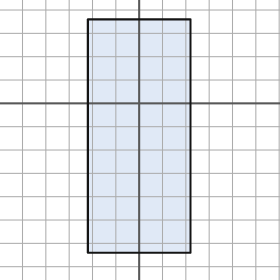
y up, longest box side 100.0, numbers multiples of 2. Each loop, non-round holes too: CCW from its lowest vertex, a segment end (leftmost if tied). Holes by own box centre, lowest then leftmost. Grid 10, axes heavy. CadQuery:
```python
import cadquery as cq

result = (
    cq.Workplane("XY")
    .moveTo(-22.0, -64.0)
    .lineTo(22.0, -64.0)
    .lineTo(22.0, 36.0)
    .lineTo(-22.0, 36.0)
    .close()
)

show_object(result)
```